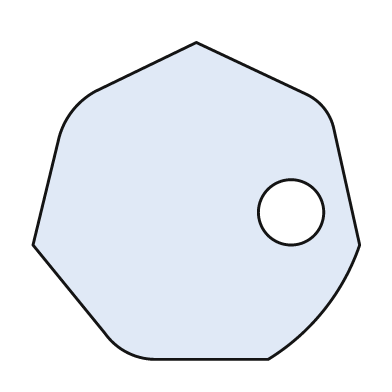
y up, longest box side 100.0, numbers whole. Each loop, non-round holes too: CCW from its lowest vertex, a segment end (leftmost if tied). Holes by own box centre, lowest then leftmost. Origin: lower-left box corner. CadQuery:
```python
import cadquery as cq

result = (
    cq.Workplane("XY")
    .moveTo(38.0, 0.0)
    .lineTo(72.0, 0.0)
    .threePointArc((89.0, 15.0), (100.0, 35.0))
    .lineTo(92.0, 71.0)
    .threePointArc((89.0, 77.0), (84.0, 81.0))
    .lineTo(50.0, 97.0)
    .lineTo(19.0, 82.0)
    .threePointArc((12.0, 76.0), (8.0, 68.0))
    .lineTo(0.0, 35.0)
    .lineTo(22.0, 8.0)
    .threePointArc((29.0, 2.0), (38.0, 0.0))
    .close()
    .moveTo(79.0, 45.0)
    .circle(10.0)
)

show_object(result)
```